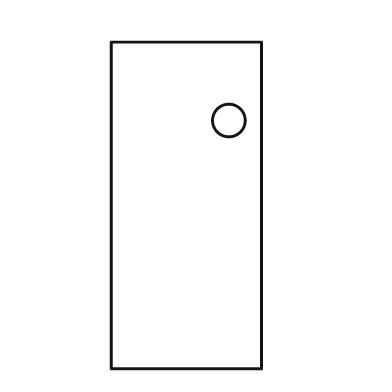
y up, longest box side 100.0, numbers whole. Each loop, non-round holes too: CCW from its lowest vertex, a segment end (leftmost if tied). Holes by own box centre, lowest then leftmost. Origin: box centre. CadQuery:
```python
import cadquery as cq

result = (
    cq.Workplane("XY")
    .moveTo(-23.0, -50.0)
    .lineTo(23.0, -50.0)
    .lineTo(23.0, 50.0)
    .lineTo(-23.0, 50.0)
    .close()
    .moveTo(13.0, 26.0)
    .circle(5.0)
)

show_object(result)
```